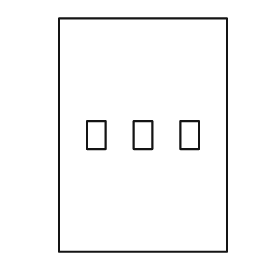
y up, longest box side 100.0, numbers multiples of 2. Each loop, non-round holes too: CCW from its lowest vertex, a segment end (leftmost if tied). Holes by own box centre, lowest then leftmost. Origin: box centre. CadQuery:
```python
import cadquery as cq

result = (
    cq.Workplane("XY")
    .moveTo(-36.0, -50.0)
    .lineTo(36.0, -50.0)
    .lineTo(36.0, 50.0)
    .lineTo(-36.0, 50.0)
    .close()
    .moveTo(-24.0, -6.0)
    .lineTo(-16.0, -6.0)
    .lineTo(-16.0, 6.0)
    .lineTo(-24.0, 6.0)
    .close()
    .moveTo(-4.0, -6.0)
    .lineTo(4.0, -6.0)
    .lineTo(4.0, 6.0)
    .lineTo(-4.0, 6.0)
    .close()
    .moveTo(16.0, -6.0)
    .lineTo(24.0, -6.0)
    .lineTo(24.0, 6.0)
    .lineTo(16.0, 6.0)
    .close()
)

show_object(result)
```